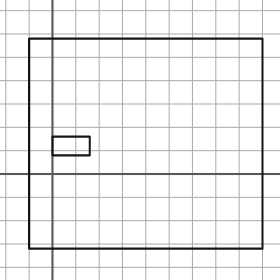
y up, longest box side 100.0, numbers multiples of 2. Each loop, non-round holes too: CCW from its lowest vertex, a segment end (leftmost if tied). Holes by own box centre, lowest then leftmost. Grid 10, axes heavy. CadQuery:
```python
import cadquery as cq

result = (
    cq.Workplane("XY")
    .moveTo(-10.0, -32.0)
    .lineTo(90.0, -32.0)
    .lineTo(90.0, 58.0)
    .lineTo(-10.0, 58.0)
    .close()
    .moveTo(0.0, 8.0)
    .lineTo(16.0, 8.0)
    .lineTo(16.0, 16.0)
    .lineTo(0.0, 16.0)
    .close()
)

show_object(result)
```